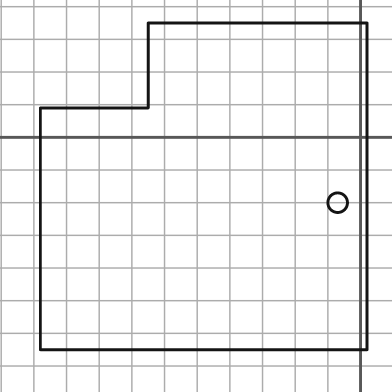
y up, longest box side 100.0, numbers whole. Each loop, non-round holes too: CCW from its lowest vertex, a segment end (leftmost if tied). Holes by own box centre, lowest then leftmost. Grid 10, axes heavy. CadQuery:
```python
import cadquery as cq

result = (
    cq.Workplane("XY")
    .moveTo(-98.0, -65.0)
    .lineTo(2.0, -65.0)
    .lineTo(2.0, 35.0)
    .lineTo(-65.0, 35.0)
    .lineTo(-65.0, 9.0)
    .lineTo(-98.0, 9.0)
    .close()
    .moveTo(-7.0, -20.0)
    .circle(3.0)
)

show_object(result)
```